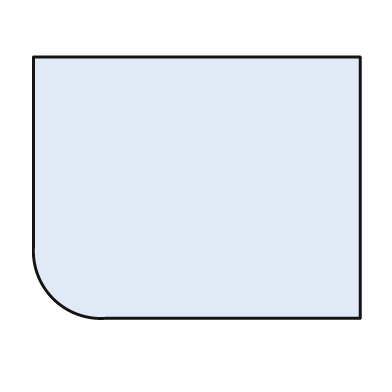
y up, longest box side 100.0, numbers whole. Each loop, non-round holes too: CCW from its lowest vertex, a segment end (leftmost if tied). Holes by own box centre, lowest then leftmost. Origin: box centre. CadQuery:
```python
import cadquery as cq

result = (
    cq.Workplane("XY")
    .moveTo(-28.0, -40.0)
    .lineTo(50.0, -40.0)
    .lineTo(50.0, 40.0)
    .lineTo(-50.0, 40.0)
    .lineTo(-50.0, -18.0)
    .threePointArc((-44.0, -34.0), (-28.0, -40.0))
    .close()
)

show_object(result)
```